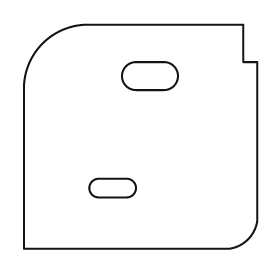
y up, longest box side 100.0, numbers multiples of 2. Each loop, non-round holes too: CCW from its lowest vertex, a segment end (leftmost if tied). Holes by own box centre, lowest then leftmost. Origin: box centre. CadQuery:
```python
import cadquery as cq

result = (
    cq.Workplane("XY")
    .moveTo(-50.0, -48.0)
    .lineTo(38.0, -48.0)
    .threePointArc((46.0, -44.0), (50.0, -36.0))
    .lineTo(50.0, 32.0)
    .lineTo(44.0, 32.0)
    .lineTo(44.0, 48.0)
    .lineTo(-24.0, 48.0)
    .threePointArc((-42.0, 40.0), (-50.0, 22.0))
    .close()
    .moveTo(-18.0, -26.0)
    .lineTo(-6.0, -26.0)
    .threePointArc((-2.0, -22.0), (-6.0, -18.0))
    .lineTo(-18.0, -18.0)
    .threePointArc((-22.0, -22.0), (-18.0, -26.0))
    .close()
    .moveTo(-2.0, 20.0)
    .lineTo(10.0, 20.0)
    .threePointArc((16.0, 26.0), (10.0, 32.0))
    .lineTo(-2.0, 32.0)
    .threePointArc((-8.0, 26.0), (-2.0, 20.0))
    .close()
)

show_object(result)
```